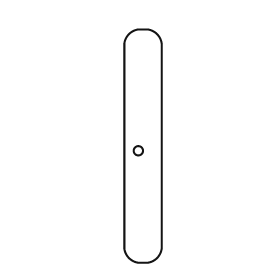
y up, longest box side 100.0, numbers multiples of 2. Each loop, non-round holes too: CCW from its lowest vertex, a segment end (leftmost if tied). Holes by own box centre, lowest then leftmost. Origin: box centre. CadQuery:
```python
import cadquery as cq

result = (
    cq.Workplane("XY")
    .moveTo(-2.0, -50.0)
    .lineTo(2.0, -50.0)
    .threePointArc((6.0, -48.0), (8.0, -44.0))
    .lineTo(8.0, 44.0)
    .threePointArc((6.0, 48.0), (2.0, 50.0))
    .lineTo(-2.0, 50.0)
    .threePointArc((-6.0, 48.0), (-8.0, 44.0))
    .lineTo(-8.0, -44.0)
    .threePointArc((-6.0, -48.0), (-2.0, -50.0))
    .close()
    .moveTo(-2.0, -2.0)
    .circle(2.0)
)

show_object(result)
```